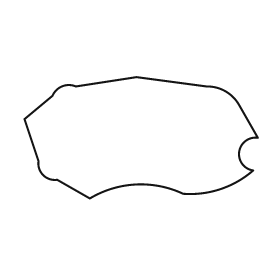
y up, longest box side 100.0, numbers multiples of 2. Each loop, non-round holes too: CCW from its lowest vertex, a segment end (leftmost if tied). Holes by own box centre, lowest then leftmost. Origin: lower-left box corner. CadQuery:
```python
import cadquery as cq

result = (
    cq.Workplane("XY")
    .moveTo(28.0, 0.0)
    .threePointArc((48.0, 6.0), (68.0, 2.0))
    .threePointArc((84.0, 4.0), (98.0, 12.0))
    .threePointArc((92.0, 20.0), (100.0, 26.0))
    .lineTo(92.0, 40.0)
    .threePointArc((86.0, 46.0), (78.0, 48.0))
    .lineTo(48.0, 52.0)
    .lineTo(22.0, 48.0)
    .threePointArc((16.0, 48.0), (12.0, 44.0))
    .lineTo(0.0, 34.0)
    .lineTo(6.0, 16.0)
    .threePointArc((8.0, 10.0), (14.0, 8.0))
    .close()
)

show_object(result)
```